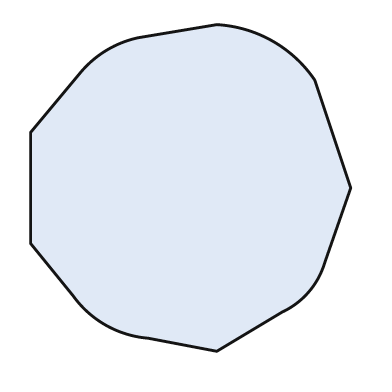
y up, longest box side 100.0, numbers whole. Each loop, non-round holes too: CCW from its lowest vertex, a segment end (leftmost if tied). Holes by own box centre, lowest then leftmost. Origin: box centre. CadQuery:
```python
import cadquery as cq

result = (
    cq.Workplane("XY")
    .moveTo(8.0, -50.0)
    .lineTo(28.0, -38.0)
    .threePointArc((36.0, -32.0), (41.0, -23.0))
    .lineTo(49.0, 0.0)
    .lineTo(38.0, 33.0)
    .threePointArc((25.0, 45.0), (8.0, 50.0))
    .lineTo(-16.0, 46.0)
    .threePointArc((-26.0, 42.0), (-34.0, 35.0))
    .lineTo(-49.0, 17.0)
    .lineTo(-49.0, -17.0)
    .lineTo(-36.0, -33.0)
    .threePointArc((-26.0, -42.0), (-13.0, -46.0))
    .close()
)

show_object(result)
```